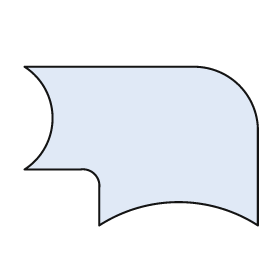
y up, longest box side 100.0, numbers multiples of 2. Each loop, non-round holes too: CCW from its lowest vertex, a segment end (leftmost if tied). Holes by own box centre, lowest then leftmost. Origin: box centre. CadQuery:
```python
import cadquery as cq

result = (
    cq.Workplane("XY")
    .moveTo(-18.0, -34.0)
    .threePointArc((16.0, -24.0), (50.0, -34.0))
    .lineTo(50.0, 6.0)
    .threePointArc((42.0, 26.0), (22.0, 34.0))
    .lineTo(-50.0, 34.0)
    .threePointArc((-38.0, 12.0), (-50.0, -10.0))
    .lineTo(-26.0, -10.0)
    .threePointArc((-20.0, -12.0), (-18.0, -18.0))
    .close()
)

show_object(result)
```